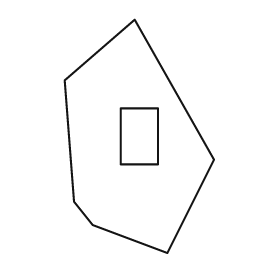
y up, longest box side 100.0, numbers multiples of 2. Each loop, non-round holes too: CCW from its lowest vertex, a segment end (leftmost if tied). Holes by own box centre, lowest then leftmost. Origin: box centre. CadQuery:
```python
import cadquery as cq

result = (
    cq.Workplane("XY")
    .moveTo(12.0, -50.0)
    .lineTo(32.0, -10.0)
    .lineTo(-2.0, 50.0)
    .lineTo(-32.0, 24.0)
    .lineTo(-28.0, -28.0)
    .lineTo(-20.0, -38.0)
    .close()
    .moveTo(-8.0, -12.0)
    .lineTo(8.0, -12.0)
    .lineTo(8.0, 12.0)
    .lineTo(-8.0, 12.0)
    .close()
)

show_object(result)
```